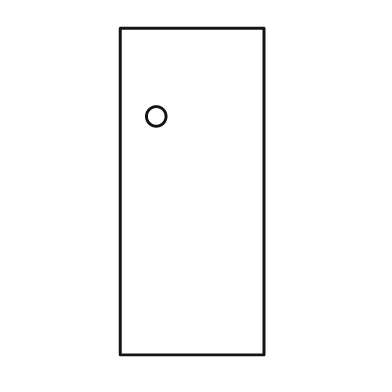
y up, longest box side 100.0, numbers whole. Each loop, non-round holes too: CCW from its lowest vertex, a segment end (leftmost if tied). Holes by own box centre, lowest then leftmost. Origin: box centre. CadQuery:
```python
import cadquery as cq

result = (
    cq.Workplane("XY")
    .moveTo(-22.0, -50.0)
    .lineTo(22.0, -50.0)
    .lineTo(22.0, 50.0)
    .lineTo(-22.0, 50.0)
    .close()
    .moveTo(-11.0, 23.0)
    .circle(3.0)
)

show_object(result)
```